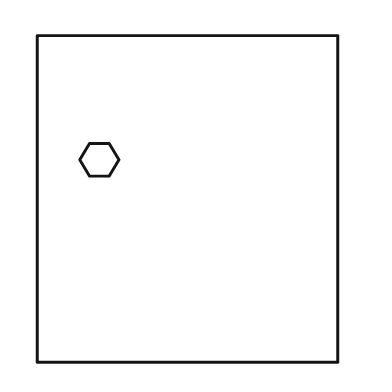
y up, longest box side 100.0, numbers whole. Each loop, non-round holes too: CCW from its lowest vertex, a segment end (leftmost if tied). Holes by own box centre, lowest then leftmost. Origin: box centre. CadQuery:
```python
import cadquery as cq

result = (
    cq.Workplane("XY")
    .moveTo(-46.0, -50.0)
    .lineTo(46.0, -50.0)
    .lineTo(46.0, 50.0)
    .lineTo(-46.0, 50.0)
    .close()
    .moveTo(-30.0, 7.0)
    .lineTo(-24.0, 7.0)
    .lineTo(-21.0, 12.0)
    .lineTo(-24.0, 17.0)
    .lineTo(-30.0, 17.0)
    .lineTo(-33.0, 12.0)
    .close()
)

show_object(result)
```